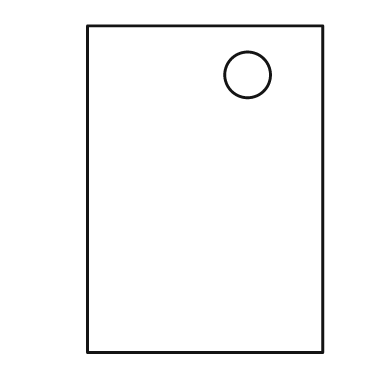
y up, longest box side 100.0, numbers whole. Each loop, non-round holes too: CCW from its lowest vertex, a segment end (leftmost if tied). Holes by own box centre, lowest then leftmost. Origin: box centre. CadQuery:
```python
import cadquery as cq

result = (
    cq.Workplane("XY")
    .moveTo(-36.0, -50.0)
    .lineTo(36.0, -50.0)
    .lineTo(36.0, 50.0)
    .lineTo(-36.0, 50.0)
    .close()
    .moveTo(13.0, 35.0)
    .circle(7.0)
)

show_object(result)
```